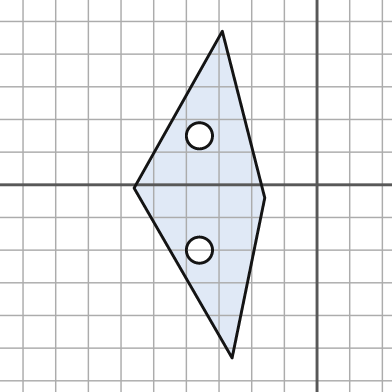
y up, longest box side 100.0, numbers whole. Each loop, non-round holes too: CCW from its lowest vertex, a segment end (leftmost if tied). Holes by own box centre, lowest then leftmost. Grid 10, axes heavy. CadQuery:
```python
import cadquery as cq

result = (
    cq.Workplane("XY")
    .moveTo(-26.0, -53.0)
    .lineTo(-16.0, -4.0)
    .lineTo(-29.0, 47.0)
    .lineTo(-56.0, -1.0)
    .close()
    .moveTo(-36.0, -20.0)
    .circle(4.0)
    .moveTo(-36.0, 15.0)
    .circle(4.0)
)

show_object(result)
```